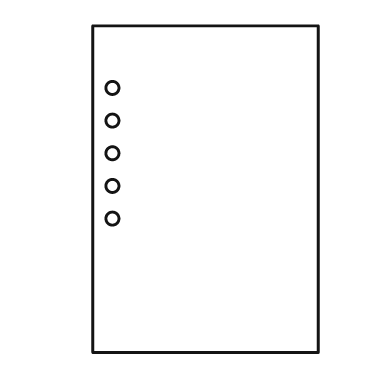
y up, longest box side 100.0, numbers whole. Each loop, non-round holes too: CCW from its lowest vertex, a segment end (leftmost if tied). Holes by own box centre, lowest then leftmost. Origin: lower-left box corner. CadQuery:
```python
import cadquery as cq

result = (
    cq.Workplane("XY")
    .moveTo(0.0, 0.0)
    .lineTo(69.0, 0.0)
    .lineTo(69.0, 100.0)
    .lineTo(0.0, 100.0)
    .close()
    .moveTo(6.0, 41.0)
    .circle(2.0)
    .moveTo(6.0, 51.0)
    .circle(2.0)
    .moveTo(6.0, 61.0)
    .circle(2.0)
    .moveTo(6.0, 71.0)
    .circle(2.0)
    .moveTo(6.0, 81.0)
    .circle(2.0)
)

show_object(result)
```